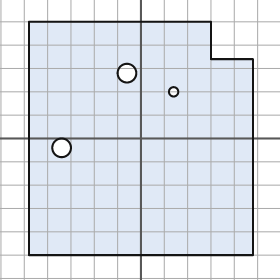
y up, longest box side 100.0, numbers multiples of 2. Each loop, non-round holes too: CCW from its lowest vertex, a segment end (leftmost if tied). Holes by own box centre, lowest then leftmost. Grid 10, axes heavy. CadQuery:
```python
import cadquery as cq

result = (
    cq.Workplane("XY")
    .moveTo(-48.0, -50.0)
    .lineTo(48.0, -50.0)
    .lineTo(48.0, 34.0)
    .lineTo(30.0, 34.0)
    .lineTo(30.0, 50.0)
    .lineTo(-48.0, 50.0)
    .close()
    .moveTo(-34.0, -4.0)
    .circle(4.0)
    .moveTo(14.0, 20.0)
    .circle(2.0)
    .moveTo(-6.0, 28.0)
    .circle(4.0)
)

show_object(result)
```